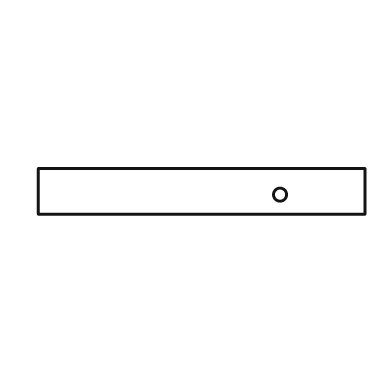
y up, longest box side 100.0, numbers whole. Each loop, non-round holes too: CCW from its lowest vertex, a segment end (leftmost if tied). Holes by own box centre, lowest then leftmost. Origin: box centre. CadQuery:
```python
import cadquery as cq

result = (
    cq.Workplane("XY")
    .moveTo(-50.0, -7.0)
    .lineTo(50.0, -7.0)
    .lineTo(50.0, 7.0)
    .lineTo(-50.0, 7.0)
    .close()
    .moveTo(24.0, -1.0)
    .circle(2.0)
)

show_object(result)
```